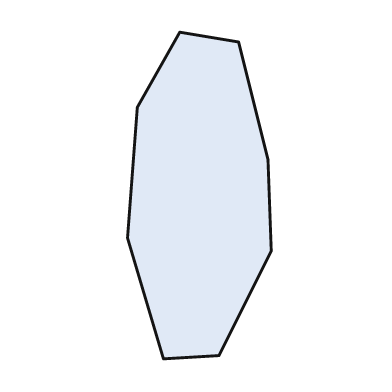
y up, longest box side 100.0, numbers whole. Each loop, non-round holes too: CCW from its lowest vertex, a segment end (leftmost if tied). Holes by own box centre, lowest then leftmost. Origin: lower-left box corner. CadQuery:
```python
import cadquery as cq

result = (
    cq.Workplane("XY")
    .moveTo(11.0, 0.0)
    .lineTo(28.0, 1.0)
    .lineTo(44.0, 33.0)
    .lineTo(43.0, 61.0)
    .lineTo(34.0, 97.0)
    .lineTo(16.0, 100.0)
    .lineTo(3.0, 77.0)
    .lineTo(0.0, 37.0)
    .close()
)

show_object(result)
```